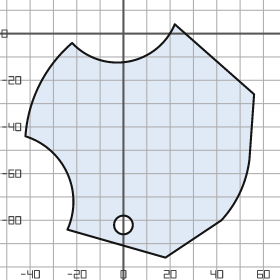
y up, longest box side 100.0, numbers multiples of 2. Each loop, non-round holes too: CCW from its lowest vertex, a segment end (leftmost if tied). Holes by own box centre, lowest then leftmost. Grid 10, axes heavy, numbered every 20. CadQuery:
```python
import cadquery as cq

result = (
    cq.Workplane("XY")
    .moveTo(18.0, -96.0)
    .lineTo(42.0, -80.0)
    .threePointArc((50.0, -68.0), (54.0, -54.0))
    .lineTo(56.0, -26.0)
    .lineTo(22.0, 4.0)
    .threePointArc((2.0, -12.0), (-22.0, -4.0))
    .threePointArc((-36.0, -22.0), (-42.0, -44.0))
    .threePointArc((-24.0, -60.0), (-24.0, -84.0))
    .close()
    .moveTo(0.0, -82.0)
    .circle(4.0)
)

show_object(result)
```